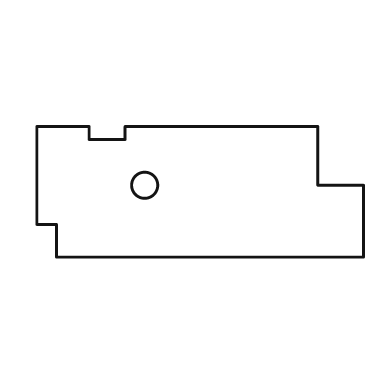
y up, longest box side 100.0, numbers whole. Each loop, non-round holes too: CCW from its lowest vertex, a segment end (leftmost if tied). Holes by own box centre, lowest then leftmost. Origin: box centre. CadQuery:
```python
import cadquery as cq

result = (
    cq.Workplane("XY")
    .moveTo(-44.0, -20.0)
    .lineTo(50.0, -20.0)
    .lineTo(50.0, 2.0)
    .lineTo(36.0, 2.0)
    .lineTo(36.0, 20.0)
    .lineTo(-23.0, 20.0)
    .lineTo(-23.0, 16.0)
    .lineTo(-34.0, 16.0)
    .lineTo(-34.0, 20.0)
    .lineTo(-50.0, 20.0)
    .lineTo(-50.0, -10.0)
    .lineTo(-44.0, -10.0)
    .close()
    .moveTo(-17.0, 2.0)
    .circle(4.0)
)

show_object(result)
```